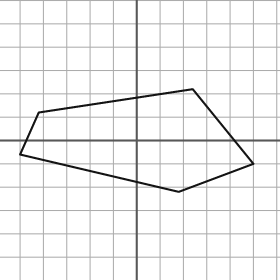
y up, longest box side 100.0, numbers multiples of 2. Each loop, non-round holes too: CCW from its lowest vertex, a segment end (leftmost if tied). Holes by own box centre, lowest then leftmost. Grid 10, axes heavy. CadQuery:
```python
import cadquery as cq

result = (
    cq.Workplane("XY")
    .moveTo(18.0, -22.0)
    .lineTo(50.0, -10.0)
    .lineTo(24.0, 22.0)
    .lineTo(-42.0, 12.0)
    .lineTo(-50.0, -6.0)
    .close()
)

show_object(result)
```